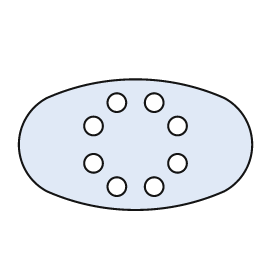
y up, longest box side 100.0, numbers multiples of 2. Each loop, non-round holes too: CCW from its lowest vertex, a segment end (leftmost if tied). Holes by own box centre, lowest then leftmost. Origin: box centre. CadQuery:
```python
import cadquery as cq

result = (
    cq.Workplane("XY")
    .moveTo(-38.0, -20.0)
    .threePointArc((0.0, -28.0), (38.0, -20.0))
    .threePointArc((50.0, 0.0), (38.0, 20.0))
    .threePointArc((0.0, 28.0), (-38.0, 20.0))
    .threePointArc((-50.0, 0.0), (-38.0, -20.0))
    .close()
    .moveTo(-8.0, -18.0)
    .circle(4.0)
    .moveTo(8.0, -18.0)
    .circle(4.0)
    .moveTo(-18.0, -8.0)
    .circle(4.0)
    .moveTo(18.0, -8.0)
    .circle(4.0)
    .moveTo(-18.0, 8.0)
    .circle(4.0)
    .moveTo(18.0, 8.0)
    .circle(4.0)
    .moveTo(-8.0, 18.0)
    .circle(4.0)
    .moveTo(8.0, 18.0)
    .circle(4.0)
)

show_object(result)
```